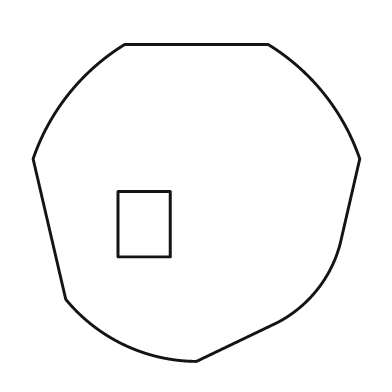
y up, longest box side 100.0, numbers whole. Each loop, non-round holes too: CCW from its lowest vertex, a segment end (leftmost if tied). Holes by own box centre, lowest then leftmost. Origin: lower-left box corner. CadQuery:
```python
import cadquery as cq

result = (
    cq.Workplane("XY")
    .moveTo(50.0, 0.0)
    .lineTo(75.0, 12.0)
    .threePointArc((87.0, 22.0), (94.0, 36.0))
    .lineTo(100.0, 62.0)
    .threePointArc((89.0, 82.0), (72.0, 97.0))
    .lineTo(28.0, 97.0)
    .threePointArc((11.0, 82.0), (0.0, 62.0))
    .lineTo(10.0, 19.0)
    .threePointArc((28.0, 5.0), (50.0, 0.0))
    .close()
    .moveTo(26.0, 32.0)
    .lineTo(42.0, 32.0)
    .lineTo(42.0, 52.0)
    .lineTo(26.0, 52.0)
    .close()
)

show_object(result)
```